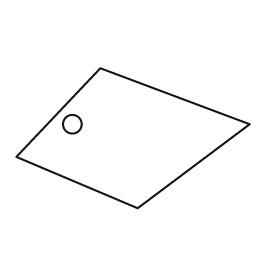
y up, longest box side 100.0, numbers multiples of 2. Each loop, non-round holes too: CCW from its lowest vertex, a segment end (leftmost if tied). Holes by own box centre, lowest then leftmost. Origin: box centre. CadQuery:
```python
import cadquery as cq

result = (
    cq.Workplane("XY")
    .moveTo(2.0, -30.0)
    .lineTo(50.0, 6.0)
    .lineTo(-14.0, 30.0)
    .lineTo(-50.0, -8.0)
    .close()
    .moveTo(-26.0, 6.0)
    .circle(4.0)
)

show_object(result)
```